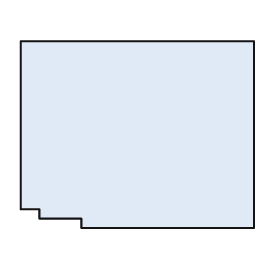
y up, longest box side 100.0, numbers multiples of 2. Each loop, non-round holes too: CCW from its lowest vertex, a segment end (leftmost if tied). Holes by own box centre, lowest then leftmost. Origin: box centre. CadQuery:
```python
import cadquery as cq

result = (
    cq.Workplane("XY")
    .moveTo(-24.0, -40.0)
    .lineTo(50.0, -40.0)
    .lineTo(50.0, 40.0)
    .lineTo(-50.0, 40.0)
    .lineTo(-50.0, -32.0)
    .lineTo(-42.0, -32.0)
    .lineTo(-42.0, -36.0)
    .lineTo(-24.0, -36.0)
    .close()
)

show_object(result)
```